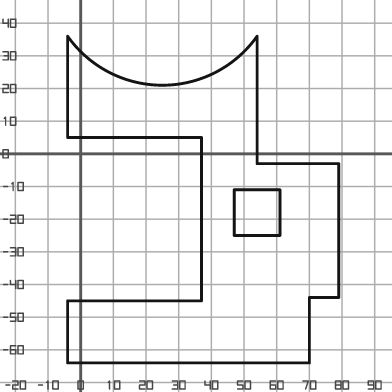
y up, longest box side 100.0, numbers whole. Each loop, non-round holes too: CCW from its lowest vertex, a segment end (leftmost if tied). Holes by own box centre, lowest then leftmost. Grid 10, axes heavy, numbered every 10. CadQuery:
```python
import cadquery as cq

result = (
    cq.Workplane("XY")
    .moveTo(-4.0, -64.0)
    .lineTo(70.0, -64.0)
    .lineTo(70.0, -44.0)
    .lineTo(79.0, -44.0)
    .lineTo(79.0, -3.0)
    .lineTo(54.0, -3.0)
    .lineTo(54.0, 36.0)
    .threePointArc((25.0, 21.0), (-4.0, 36.0))
    .lineTo(-4.0, 5.0)
    .lineTo(37.0, 5.0)
    .lineTo(37.0, -45.0)
    .lineTo(-4.0, -45.0)
    .close()
    .moveTo(47.0, -25.0)
    .lineTo(61.0, -25.0)
    .lineTo(61.0, -11.0)
    .lineTo(47.0, -11.0)
    .close()
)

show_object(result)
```